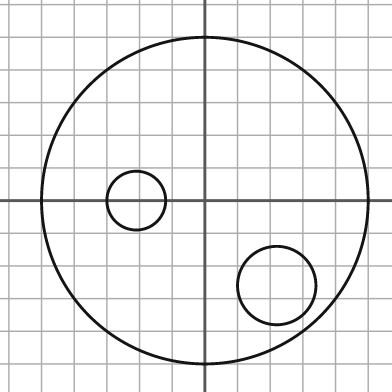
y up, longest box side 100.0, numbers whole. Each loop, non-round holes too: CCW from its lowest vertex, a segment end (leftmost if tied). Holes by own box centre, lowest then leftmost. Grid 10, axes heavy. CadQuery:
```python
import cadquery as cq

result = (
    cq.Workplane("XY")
    .moveTo(0.0, 0.0)
    .circle(50.0)
    .moveTo(22.0, -26.0)
    .circle(12.0)
    .moveTo(-21.0, 0.0)
    .circle(9.0)
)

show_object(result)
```